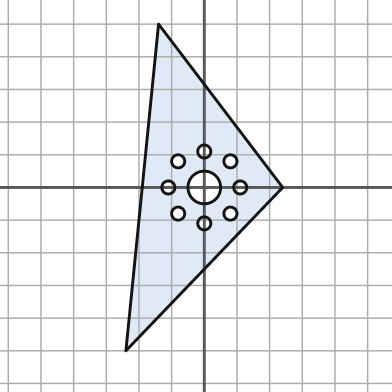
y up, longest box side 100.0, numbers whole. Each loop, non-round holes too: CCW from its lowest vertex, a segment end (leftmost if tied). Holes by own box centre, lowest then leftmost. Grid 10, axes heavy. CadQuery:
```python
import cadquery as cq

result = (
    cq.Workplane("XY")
    .moveTo(-24.0, -50.0)
    .lineTo(24.0, 0.0)
    .lineTo(-14.0, 50.0)
    .close()
    .moveTo(0.0, -11.0)
    .circle(2.0)
    .moveTo(-8.0, -8.0)
    .circle(2.0)
    .moveTo(8.0, -8.0)
    .circle(2.0)
    .moveTo(-11.0, 0.0)
    .circle(2.0)
    .moveTo(0.0, 0.0)
    .circle(5.0)
    .moveTo(11.0, 0.0)
    .circle(2.0)
    .moveTo(-8.0, 8.0)
    .circle(2.0)
    .moveTo(8.0, 8.0)
    .circle(2.0)
    .moveTo(0.0, 11.0)
    .circle(2.0)
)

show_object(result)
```